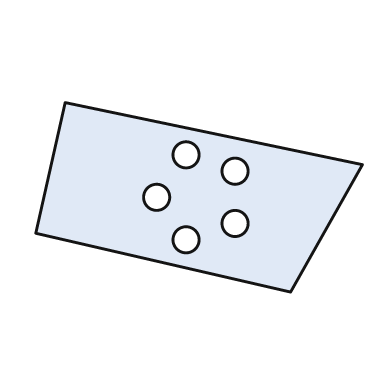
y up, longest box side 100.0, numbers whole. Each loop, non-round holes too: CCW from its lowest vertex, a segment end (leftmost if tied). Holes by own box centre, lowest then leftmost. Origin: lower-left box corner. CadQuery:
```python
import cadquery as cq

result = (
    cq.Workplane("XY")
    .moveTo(78.0, 0.0)
    .lineTo(100.0, 39.0)
    .lineTo(9.0, 58.0)
    .lineTo(0.0, 18.0)
    .close()
    .moveTo(46.0, 16.0)
    .circle(4.0)
    .moveTo(61.0, 21.0)
    .circle(4.0)
    .moveTo(37.0, 29.0)
    .circle(4.0)
    .moveTo(61.0, 37.0)
    .circle(4.0)
    .moveTo(46.0, 42.0)
    .circle(4.0)
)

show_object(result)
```